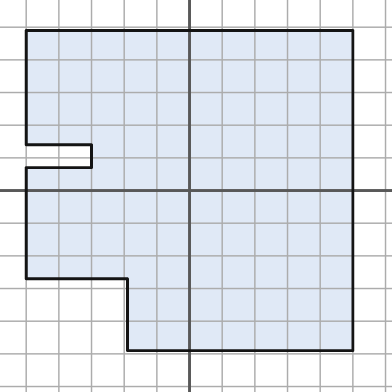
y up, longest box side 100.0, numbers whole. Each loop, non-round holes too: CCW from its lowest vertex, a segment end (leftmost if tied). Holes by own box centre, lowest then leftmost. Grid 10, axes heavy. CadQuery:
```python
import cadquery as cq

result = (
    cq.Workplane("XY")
    .moveTo(-19.0, -49.0)
    .lineTo(50.0, -49.0)
    .lineTo(50.0, 49.0)
    .lineTo(-50.0, 49.0)
    .lineTo(-50.0, 14.0)
    .lineTo(-30.0, 14.0)
    .lineTo(-30.0, 7.0)
    .lineTo(-50.0, 7.0)
    .lineTo(-50.0, -27.0)
    .lineTo(-19.0, -27.0)
    .close()
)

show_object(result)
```